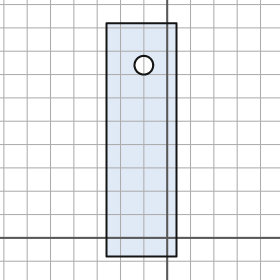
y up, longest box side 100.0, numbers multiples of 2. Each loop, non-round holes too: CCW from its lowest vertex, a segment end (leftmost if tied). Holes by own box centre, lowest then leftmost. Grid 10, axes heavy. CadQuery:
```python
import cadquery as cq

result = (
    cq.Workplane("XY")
    .moveTo(-26.0, -8.0)
    .lineTo(4.0, -8.0)
    .lineTo(4.0, 92.0)
    .lineTo(-26.0, 92.0)
    .close()
    .moveTo(-10.0, 74.0)
    .circle(4.0)
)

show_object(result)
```